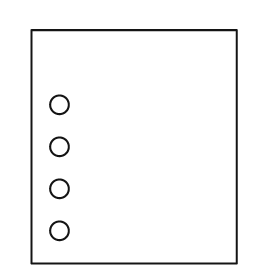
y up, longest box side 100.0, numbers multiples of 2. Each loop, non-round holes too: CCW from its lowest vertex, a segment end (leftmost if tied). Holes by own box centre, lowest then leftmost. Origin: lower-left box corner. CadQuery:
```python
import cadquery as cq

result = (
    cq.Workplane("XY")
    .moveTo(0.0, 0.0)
    .lineTo(88.0, 0.0)
    .lineTo(88.0, 100.0)
    .lineTo(0.0, 100.0)
    .close()
    .moveTo(12.0, 14.0)
    .circle(4.0)
    .moveTo(12.0, 32.0)
    .circle(4.0)
    .moveTo(12.0, 50.0)
    .circle(4.0)
    .moveTo(12.0, 68.0)
    .circle(4.0)
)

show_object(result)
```